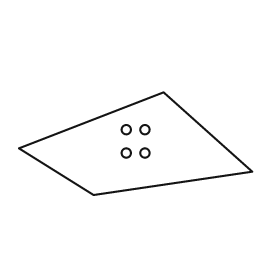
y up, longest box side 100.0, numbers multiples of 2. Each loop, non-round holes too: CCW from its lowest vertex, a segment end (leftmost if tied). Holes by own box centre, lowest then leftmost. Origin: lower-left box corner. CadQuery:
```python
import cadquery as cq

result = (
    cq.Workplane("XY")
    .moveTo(32.0, 0.0)
    .lineTo(100.0, 10.0)
    .lineTo(62.0, 44.0)
    .lineTo(0.0, 20.0)
    .close()
    .moveTo(46.0, 18.0)
    .circle(2.0)
    .moveTo(54.0, 18.0)
    .circle(2.0)
    .moveTo(46.0, 28.0)
    .circle(2.0)
    .moveTo(54.0, 28.0)
    .circle(2.0)
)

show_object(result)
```